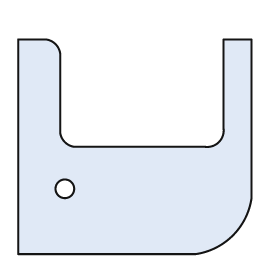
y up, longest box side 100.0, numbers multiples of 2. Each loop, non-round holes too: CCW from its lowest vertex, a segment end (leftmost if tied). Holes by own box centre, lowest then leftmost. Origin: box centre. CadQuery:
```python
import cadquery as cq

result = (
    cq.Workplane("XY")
    .moveTo(-50.0, -46.0)
    .lineTo(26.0, -46.0)
    .threePointArc((42.0, -38.0), (50.0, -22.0))
    .lineTo(50.0, 46.0)
    .lineTo(38.0, 46.0)
    .lineTo(38.0, 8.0)
    .threePointArc((36.0, 2.0), (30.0, 0.0))
    .lineTo(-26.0, 0.0)
    .threePointArc((-30.0, 2.0), (-32.0, 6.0))
    .lineTo(-32.0, 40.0)
    .threePointArc((-34.0, 44.0), (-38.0, 46.0))
    .lineTo(-50.0, 46.0)
    .close()
    .moveTo(-30.0, -18.0)
    .circle(4.0)
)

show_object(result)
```